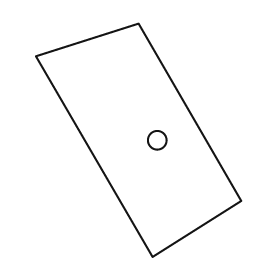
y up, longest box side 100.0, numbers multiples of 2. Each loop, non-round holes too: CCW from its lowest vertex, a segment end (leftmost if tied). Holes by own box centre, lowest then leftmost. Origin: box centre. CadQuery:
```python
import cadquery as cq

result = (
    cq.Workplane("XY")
    .moveTo(6.0, -50.0)
    .lineTo(44.0, -26.0)
    .lineTo(0.0, 50.0)
    .lineTo(-44.0, 36.0)
    .close()
    .moveTo(8.0, 0.0)
    .circle(4.0)
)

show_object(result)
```